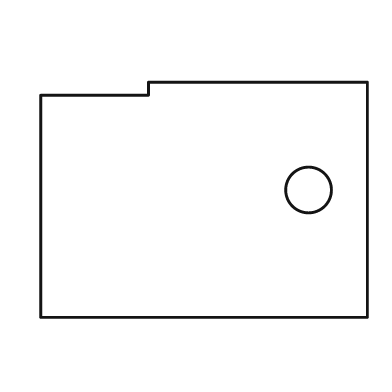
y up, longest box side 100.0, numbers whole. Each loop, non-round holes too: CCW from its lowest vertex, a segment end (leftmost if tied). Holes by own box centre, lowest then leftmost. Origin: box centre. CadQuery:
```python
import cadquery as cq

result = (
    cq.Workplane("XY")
    .moveTo(-50.0, -36.0)
    .lineTo(50.0, -36.0)
    .lineTo(50.0, 36.0)
    .lineTo(-17.0, 36.0)
    .lineTo(-17.0, 32.0)
    .lineTo(-50.0, 32.0)
    .close()
    .moveTo(32.0, 3.0)
    .circle(7.0)
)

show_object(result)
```